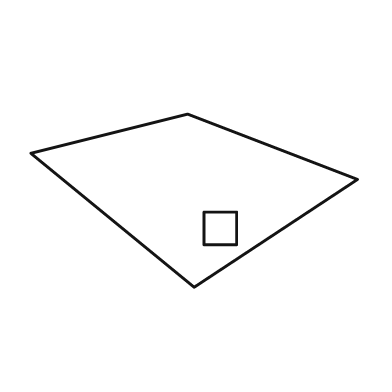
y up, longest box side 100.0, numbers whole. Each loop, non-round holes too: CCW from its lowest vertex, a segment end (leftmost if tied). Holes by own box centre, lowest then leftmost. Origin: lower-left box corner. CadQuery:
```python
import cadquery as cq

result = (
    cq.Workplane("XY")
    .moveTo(50.0, 0.0)
    .lineTo(100.0, 33.0)
    .lineTo(48.0, 53.0)
    .lineTo(0.0, 41.0)
    .close()
    .moveTo(53.0, 13.0)
    .lineTo(63.0, 13.0)
    .lineTo(63.0, 23.0)
    .lineTo(53.0, 23.0)
    .close()
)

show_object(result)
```